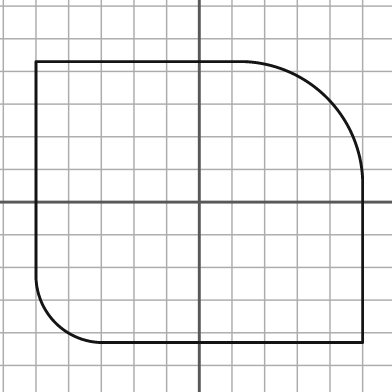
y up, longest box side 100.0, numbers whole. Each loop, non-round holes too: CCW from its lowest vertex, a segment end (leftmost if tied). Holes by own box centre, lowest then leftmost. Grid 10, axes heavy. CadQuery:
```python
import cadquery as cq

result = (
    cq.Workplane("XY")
    .moveTo(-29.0, -43.0)
    .lineTo(50.0, -43.0)
    .lineTo(50.0, 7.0)
    .threePointArc((39.0, 32.0), (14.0, 43.0))
    .lineTo(-50.0, 43.0)
    .lineTo(-50.0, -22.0)
    .threePointArc((-44.0, -37.0), (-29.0, -43.0))
    .close()
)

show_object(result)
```